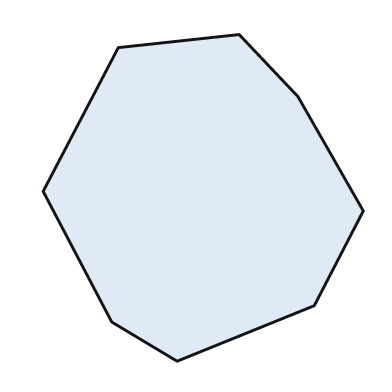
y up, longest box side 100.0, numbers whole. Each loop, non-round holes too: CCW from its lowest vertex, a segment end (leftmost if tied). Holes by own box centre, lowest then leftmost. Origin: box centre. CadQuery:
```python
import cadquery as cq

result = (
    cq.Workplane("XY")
    .moveTo(-8.0, -50.0)
    .lineTo(34.0, -33.0)
    .lineTo(49.0, -4.0)
    .lineTo(29.0, 31.0)
    .lineTo(11.0, 50.0)
    .lineTo(-26.0, 46.0)
    .lineTo(-49.0, 2.0)
    .lineTo(-28.0, -38.0)
    .close()
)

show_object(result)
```